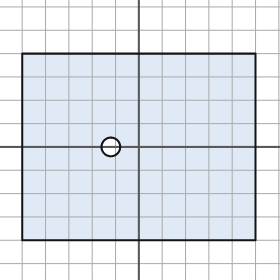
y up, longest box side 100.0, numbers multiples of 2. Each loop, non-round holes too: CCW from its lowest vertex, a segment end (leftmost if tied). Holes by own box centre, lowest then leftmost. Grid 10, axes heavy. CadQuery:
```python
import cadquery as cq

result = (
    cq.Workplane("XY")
    .moveTo(-50.0, -40.0)
    .lineTo(50.0, -40.0)
    .lineTo(50.0, 40.0)
    .lineTo(-50.0, 40.0)
    .close()
    .moveTo(-12.0, 0.0)
    .circle(4.0)
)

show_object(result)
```